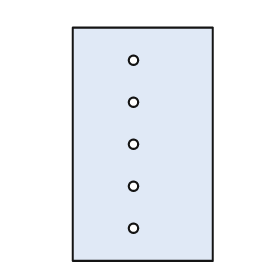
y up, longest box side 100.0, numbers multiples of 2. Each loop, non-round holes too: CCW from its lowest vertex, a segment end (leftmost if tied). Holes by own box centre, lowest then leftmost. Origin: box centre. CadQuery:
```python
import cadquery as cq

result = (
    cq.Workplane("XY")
    .moveTo(-30.0, -50.0)
    .lineTo(30.0, -50.0)
    .lineTo(30.0, 50.0)
    .lineTo(-30.0, 50.0)
    .close()
    .moveTo(-4.0, -36.0)
    .circle(2.0)
    .moveTo(-4.0, -18.0)
    .circle(2.0)
    .moveTo(-4.0, 0.0)
    .circle(2.0)
    .moveTo(-4.0, 18.0)
    .circle(2.0)
    .moveTo(-4.0, 36.0)
    .circle(2.0)
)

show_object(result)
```